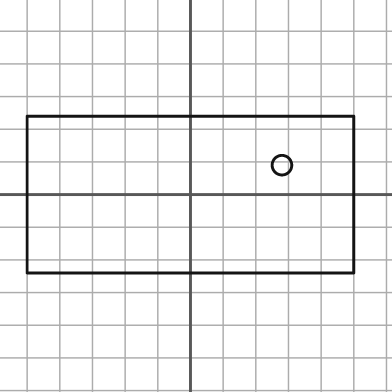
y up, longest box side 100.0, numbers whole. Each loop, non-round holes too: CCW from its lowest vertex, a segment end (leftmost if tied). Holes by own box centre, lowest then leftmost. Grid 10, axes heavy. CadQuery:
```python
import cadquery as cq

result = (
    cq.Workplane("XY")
    .moveTo(-50.0, -24.0)
    .lineTo(50.0, -24.0)
    .lineTo(50.0, 24.0)
    .lineTo(-50.0, 24.0)
    .close()
    .moveTo(28.0, 9.0)
    .circle(3.0)
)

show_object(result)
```